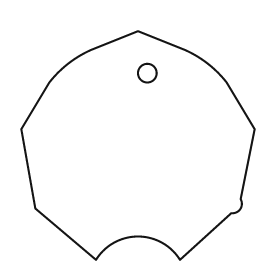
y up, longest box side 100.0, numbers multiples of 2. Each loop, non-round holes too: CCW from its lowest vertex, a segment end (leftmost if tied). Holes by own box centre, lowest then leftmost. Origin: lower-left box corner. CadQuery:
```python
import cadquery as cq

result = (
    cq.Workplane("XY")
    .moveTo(32.0, 0.0)
    .threePointArc((50.0, 10.0), (68.0, 0.0))
    .lineTo(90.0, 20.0)
    .threePointArc((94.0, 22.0), (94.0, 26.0))
    .lineTo(100.0, 56.0)
    .lineTo(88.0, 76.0)
    .threePointArc((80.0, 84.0), (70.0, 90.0))
    .lineTo(50.0, 98.0)
    .lineTo(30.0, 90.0)
    .threePointArc((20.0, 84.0), (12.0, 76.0))
    .lineTo(0.0, 56.0)
    .lineTo(6.0, 22.0)
    .close()
    .moveTo(54.0, 80.0)
    .circle(4.0)
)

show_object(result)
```